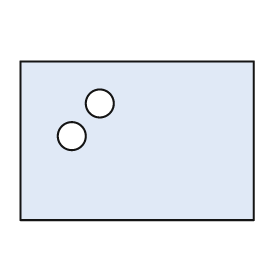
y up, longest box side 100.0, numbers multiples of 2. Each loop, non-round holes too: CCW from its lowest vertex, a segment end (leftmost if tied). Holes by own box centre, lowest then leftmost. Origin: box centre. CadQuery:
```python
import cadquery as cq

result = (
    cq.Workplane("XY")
    .moveTo(-50.0, -34.0)
    .lineTo(50.0, -34.0)
    .lineTo(50.0, 34.0)
    .lineTo(-50.0, 34.0)
    .close()
    .moveTo(-28.0, 2.0)
    .circle(6.0)
    .moveTo(-16.0, 16.0)
    .circle(6.0)
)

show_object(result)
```